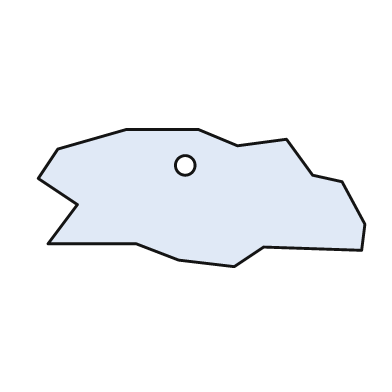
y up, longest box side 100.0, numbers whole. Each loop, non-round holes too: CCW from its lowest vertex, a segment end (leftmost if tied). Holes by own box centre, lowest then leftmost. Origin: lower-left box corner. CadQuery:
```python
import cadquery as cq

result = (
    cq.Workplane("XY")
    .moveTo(60.0, 0.0)
    .lineTo(69.0, 6.0)
    .lineTo(99.0, 5.0)
    .lineTo(100.0, 13.0)
    .lineTo(93.0, 26.0)
    .lineTo(84.0, 28.0)
    .lineTo(76.0, 39.0)
    .lineTo(61.0, 37.0)
    .lineTo(49.0, 42.0)
    .lineTo(27.0, 42.0)
    .lineTo(6.0, 36.0)
    .lineTo(0.0, 27.0)
    .lineTo(12.0, 19.0)
    .lineTo(3.0, 7.0)
    .lineTo(30.0, 7.0)
    .lineTo(43.0, 2.0)
    .close()
    .moveTo(45.0, 31.0)
    .circle(3.0)
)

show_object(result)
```